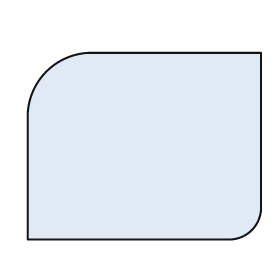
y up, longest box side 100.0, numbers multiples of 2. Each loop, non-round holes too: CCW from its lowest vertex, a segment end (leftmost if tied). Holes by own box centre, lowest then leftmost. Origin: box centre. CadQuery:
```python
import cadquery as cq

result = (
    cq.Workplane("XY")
    .moveTo(-50.0, -40.0)
    .lineTo(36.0, -40.0)
    .threePointArc((46.0, -36.0), (50.0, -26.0))
    .lineTo(50.0, 40.0)
    .lineTo(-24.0, 40.0)
    .threePointArc((-42.0, 32.0), (-50.0, 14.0))
    .close()
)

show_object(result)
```